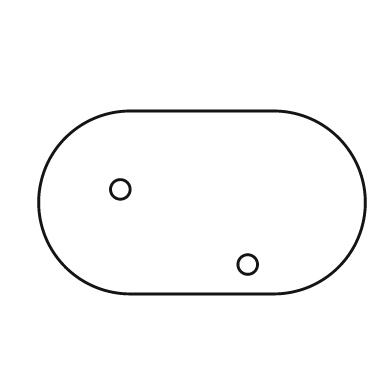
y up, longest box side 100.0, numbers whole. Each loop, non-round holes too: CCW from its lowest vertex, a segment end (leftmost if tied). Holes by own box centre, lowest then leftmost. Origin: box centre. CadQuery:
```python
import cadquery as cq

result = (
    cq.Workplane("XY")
    .moveTo(-22.0, -28.0)
    .lineTo(22.0, -28.0)
    .threePointArc((50.0, 0.0), (22.0, 28.0))
    .lineTo(-22.0, 28.0)
    .threePointArc((-50.0, 0.0), (-22.0, -28.0))
    .close()
    .moveTo(14.0, -19.0)
    .circle(3.0)
    .moveTo(-25.0, 4.0)
    .circle(3.0)
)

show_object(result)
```